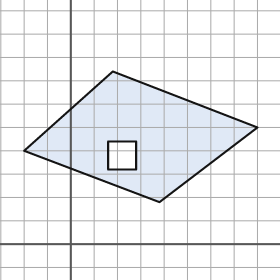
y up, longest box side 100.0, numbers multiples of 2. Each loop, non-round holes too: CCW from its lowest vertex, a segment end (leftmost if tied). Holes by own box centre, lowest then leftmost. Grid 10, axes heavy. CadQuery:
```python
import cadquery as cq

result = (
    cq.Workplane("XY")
    .moveTo(38.0, 18.0)
    .lineTo(80.0, 50.0)
    .lineTo(18.0, 74.0)
    .lineTo(-20.0, 40.0)
    .close()
    .moveTo(16.0, 32.0)
    .lineTo(28.0, 32.0)
    .lineTo(28.0, 44.0)
    .lineTo(16.0, 44.0)
    .close()
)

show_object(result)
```